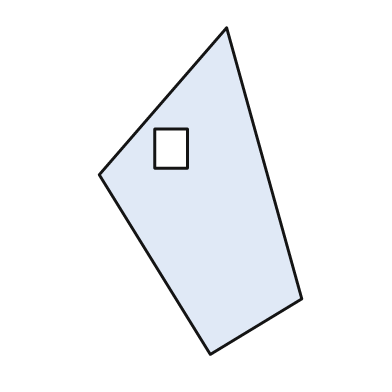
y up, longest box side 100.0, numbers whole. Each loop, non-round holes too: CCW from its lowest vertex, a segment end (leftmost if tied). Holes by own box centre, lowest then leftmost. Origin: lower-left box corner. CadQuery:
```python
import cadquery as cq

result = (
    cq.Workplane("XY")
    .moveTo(34.0, 0.0)
    .lineTo(62.0, 17.0)
    .lineTo(39.0, 100.0)
    .lineTo(0.0, 55.0)
    .close()
    .moveTo(17.0, 57.0)
    .lineTo(27.0, 57.0)
    .lineTo(27.0, 69.0)
    .lineTo(17.0, 69.0)
    .close()
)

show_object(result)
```